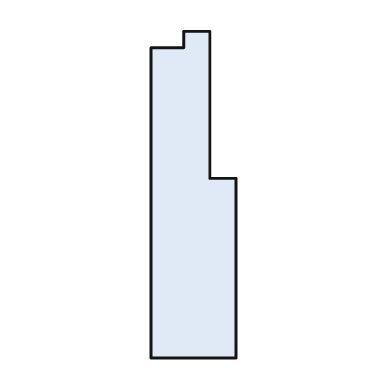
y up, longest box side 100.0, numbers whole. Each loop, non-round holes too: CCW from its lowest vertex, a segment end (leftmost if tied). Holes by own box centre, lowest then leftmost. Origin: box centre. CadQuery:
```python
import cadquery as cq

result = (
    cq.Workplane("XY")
    .moveTo(-13.0, -50.0)
    .lineTo(13.0, -50.0)
    .lineTo(13.0, 5.0)
    .lineTo(5.0, 5.0)
    .lineTo(5.0, 50.0)
    .lineTo(-3.0, 50.0)
    .lineTo(-3.0, 45.0)
    .lineTo(-13.0, 45.0)
    .close()
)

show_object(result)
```